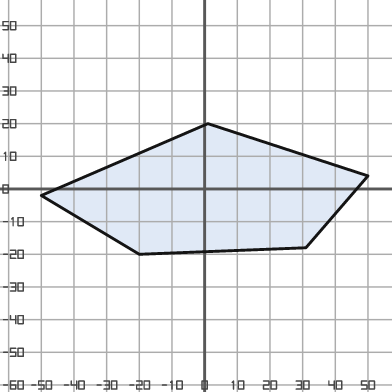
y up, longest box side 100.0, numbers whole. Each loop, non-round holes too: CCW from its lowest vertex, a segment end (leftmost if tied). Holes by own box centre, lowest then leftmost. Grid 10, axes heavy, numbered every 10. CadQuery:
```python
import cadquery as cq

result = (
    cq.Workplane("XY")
    .moveTo(-20.0, -20.0)
    .lineTo(31.0, -18.0)
    .lineTo(50.0, 4.0)
    .lineTo(1.0, 20.0)
    .lineTo(-50.0, -2.0)
    .close()
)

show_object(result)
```